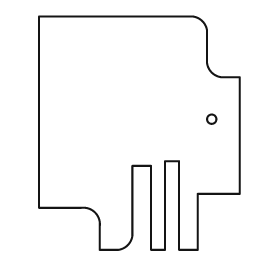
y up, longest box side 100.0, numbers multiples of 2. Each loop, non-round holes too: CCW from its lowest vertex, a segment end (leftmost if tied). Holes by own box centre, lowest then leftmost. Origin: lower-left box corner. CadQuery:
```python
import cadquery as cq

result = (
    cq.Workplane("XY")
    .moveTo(26.0, 0.0)
    .lineTo(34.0, 0.0)
    .threePointArc((38.0, 2.0), (40.0, 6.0))
    .lineTo(40.0, 36.0)
    .lineTo(48.0, 36.0)
    .lineTo(48.0, 0.0)
    .lineTo(54.0, 0.0)
    .lineTo(54.0, 38.0)
    .lineTo(60.0, 38.0)
    .lineTo(60.0, 0.0)
    .lineTo(68.0, 0.0)
    .lineTo(68.0, 24.0)
    .lineTo(86.0, 24.0)
    .lineTo(86.0, 74.0)
    .lineTo(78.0, 74.0)
    .threePointArc((74.0, 76.0), (72.0, 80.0))
    .lineTo(72.0, 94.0)
    .threePointArc((70.0, 98.0), (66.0, 100.0))
    .lineTo(0.0, 100.0)
    .lineTo(0.0, 18.0)
    .lineTo(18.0, 18.0)
    .threePointArc((24.0, 16.0), (26.0, 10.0))
    .close()
    .moveTo(74.0, 56.0)
    .circle(2.0)
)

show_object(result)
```